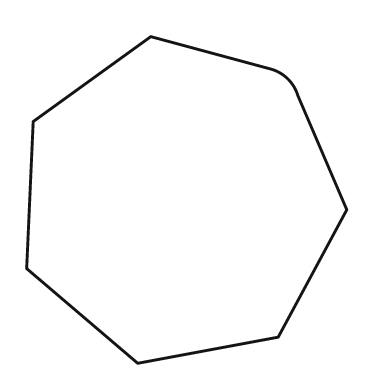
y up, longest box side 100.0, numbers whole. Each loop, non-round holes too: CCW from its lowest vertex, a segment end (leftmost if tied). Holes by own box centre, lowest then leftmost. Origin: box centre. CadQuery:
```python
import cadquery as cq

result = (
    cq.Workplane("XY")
    .moveTo(-15.0, -50.0)
    .lineTo(28.0, -42.0)
    .lineTo(49.0, -3.0)
    .lineTo(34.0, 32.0)
    .threePointArc((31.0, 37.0), (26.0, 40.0))
    .lineTo(-11.0, 50.0)
    .lineTo(-47.0, 24.0)
    .lineTo(-49.0, -21.0)
    .close()
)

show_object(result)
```